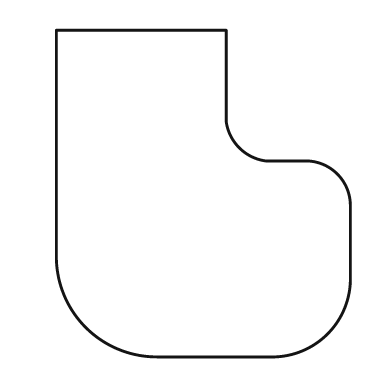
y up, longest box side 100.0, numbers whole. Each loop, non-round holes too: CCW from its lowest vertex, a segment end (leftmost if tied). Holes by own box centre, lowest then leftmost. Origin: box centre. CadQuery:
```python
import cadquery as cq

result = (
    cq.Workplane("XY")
    .moveTo(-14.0, -50.0)
    .lineTo(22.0, -50.0)
    .threePointArc((38.0, -43.0), (45.0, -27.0))
    .lineTo(45.0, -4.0)
    .threePointArc((41.0, 6.0), (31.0, 10.0))
    .lineTo(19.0, 10.0)
    .threePointArc((11.0, 14.0), (7.0, 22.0))
    .lineTo(7.0, 50.0)
    .lineTo(-45.0, 50.0)
    .lineTo(-45.0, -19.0)
    .threePointArc((-36.0, -41.0), (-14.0, -50.0))
    .close()
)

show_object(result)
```